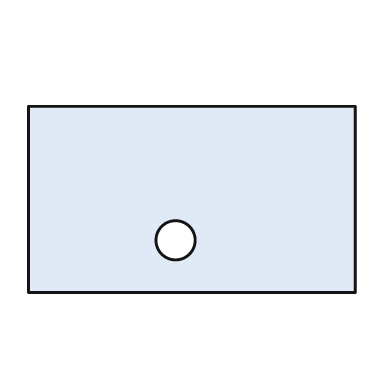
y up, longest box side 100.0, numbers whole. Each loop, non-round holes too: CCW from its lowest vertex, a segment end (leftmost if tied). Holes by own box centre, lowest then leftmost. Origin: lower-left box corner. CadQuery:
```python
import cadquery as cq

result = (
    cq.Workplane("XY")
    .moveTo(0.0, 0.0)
    .lineTo(100.0, 0.0)
    .lineTo(100.0, 57.0)
    .lineTo(0.0, 57.0)
    .close()
    .moveTo(45.0, 16.0)
    .circle(6.0)
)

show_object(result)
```